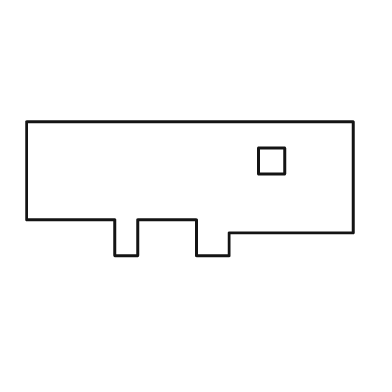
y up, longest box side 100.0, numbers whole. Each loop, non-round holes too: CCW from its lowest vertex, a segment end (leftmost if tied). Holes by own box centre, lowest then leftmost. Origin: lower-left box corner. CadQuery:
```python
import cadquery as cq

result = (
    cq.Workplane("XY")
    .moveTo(27.0, 0.0)
    .lineTo(34.0, 0.0)
    .lineTo(34.0, 11.0)
    .lineTo(52.0, 11.0)
    .lineTo(52.0, 0.0)
    .lineTo(62.0, 0.0)
    .lineTo(62.0, 7.0)
    .lineTo(100.0, 7.0)
    .lineTo(100.0, 41.0)
    .lineTo(0.0, 41.0)
    .lineTo(0.0, 11.0)
    .lineTo(27.0, 11.0)
    .close()
    .moveTo(71.0, 25.0)
    .lineTo(79.0, 25.0)
    .lineTo(79.0, 33.0)
    .lineTo(71.0, 33.0)
    .close()
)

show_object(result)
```